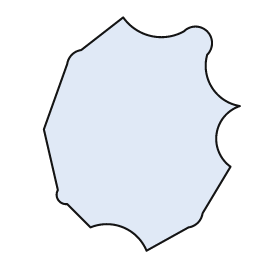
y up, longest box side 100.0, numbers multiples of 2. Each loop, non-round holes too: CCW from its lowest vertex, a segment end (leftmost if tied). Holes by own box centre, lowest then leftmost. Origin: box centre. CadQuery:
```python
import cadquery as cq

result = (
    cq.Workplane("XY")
    .moveTo(2.0, -50.0)
    .lineTo(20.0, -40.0)
    .threePointArc((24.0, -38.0), (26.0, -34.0))
    .lineTo(38.0, -14.0)
    .threePointArc((32.0, 0.0), (42.0, 12.0))
    .threePointArc((30.0, 20.0), (28.0, 34.0))
    .threePointArc((28.0, 44.0), (18.0, 44.0))
    .threePointArc((4.0, 42.0), (-8.0, 50.0))
    .lineTo(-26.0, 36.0)
    .threePointArc((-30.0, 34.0), (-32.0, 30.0))
    .lineTo(-42.0, 2.0)
    .lineTo(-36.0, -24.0)
    .threePointArc((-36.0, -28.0), (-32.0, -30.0))
    .lineTo(-22.0, -40.0)
    .threePointArc((-8.0, -40.0), (2.0, -50.0))
    .close()
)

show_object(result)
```